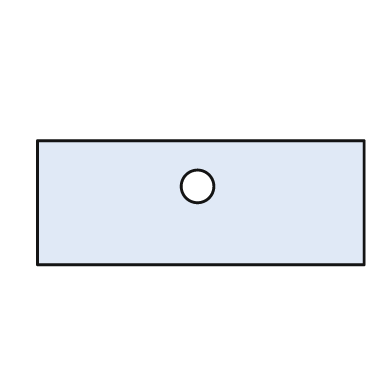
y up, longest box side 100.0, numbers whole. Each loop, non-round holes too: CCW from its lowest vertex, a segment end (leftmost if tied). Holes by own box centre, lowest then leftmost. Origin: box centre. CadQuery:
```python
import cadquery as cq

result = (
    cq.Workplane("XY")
    .moveTo(-50.0, -19.0)
    .lineTo(50.0, -19.0)
    .lineTo(50.0, 19.0)
    .lineTo(-50.0, 19.0)
    .close()
    .moveTo(-1.0, 5.0)
    .circle(5.0)
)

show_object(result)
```